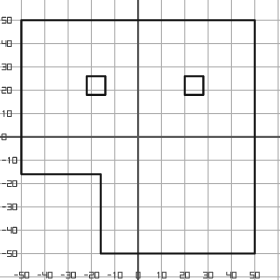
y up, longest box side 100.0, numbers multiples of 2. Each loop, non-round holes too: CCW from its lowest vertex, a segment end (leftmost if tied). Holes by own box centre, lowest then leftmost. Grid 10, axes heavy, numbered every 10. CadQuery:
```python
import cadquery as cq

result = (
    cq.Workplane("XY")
    .moveTo(-16.0, -50.0)
    .lineTo(50.0, -50.0)
    .lineTo(50.0, 50.0)
    .lineTo(-50.0, 50.0)
    .lineTo(-50.0, -16.0)
    .lineTo(-16.0, -16.0)
    .close()
    .moveTo(-22.0, 18.0)
    .lineTo(-14.0, 18.0)
    .lineTo(-14.0, 26.0)
    .lineTo(-22.0, 26.0)
    .close()
    .moveTo(20.0, 18.0)
    .lineTo(28.0, 18.0)
    .lineTo(28.0, 26.0)
    .lineTo(20.0, 26.0)
    .close()
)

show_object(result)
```